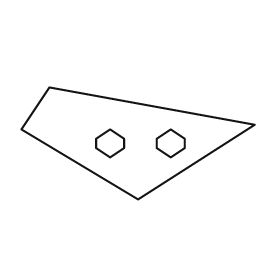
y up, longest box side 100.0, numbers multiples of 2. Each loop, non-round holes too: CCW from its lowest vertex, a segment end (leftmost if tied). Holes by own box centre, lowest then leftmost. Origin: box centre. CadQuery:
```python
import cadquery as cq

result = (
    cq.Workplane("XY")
    .moveTo(0.0, -24.0)
    .lineTo(50.0, 8.0)
    .lineTo(-38.0, 24.0)
    .lineTo(-50.0, 6.0)
    .close()
    .moveTo(-12.0, -6.0)
    .lineTo(-6.0, -2.0)
    .lineTo(-6.0, 2.0)
    .lineTo(-12.0, 6.0)
    .lineTo(-18.0, 2.0)
    .lineTo(-18.0, -2.0)
    .close()
    .moveTo(14.0, -6.0)
    .lineTo(20.0, -2.0)
    .lineTo(20.0, 2.0)
    .lineTo(14.0, 6.0)
    .lineTo(8.0, 2.0)
    .lineTo(8.0, -2.0)
    .close()
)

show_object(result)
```